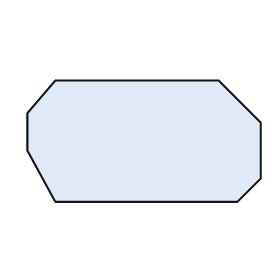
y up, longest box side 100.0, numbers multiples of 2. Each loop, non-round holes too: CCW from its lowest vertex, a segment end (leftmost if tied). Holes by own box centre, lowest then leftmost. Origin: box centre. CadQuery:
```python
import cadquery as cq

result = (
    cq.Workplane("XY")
    .moveTo(-38.0, -26.0)
    .lineTo(40.0, -26.0)
    .lineTo(50.0, -16.0)
    .lineTo(50.0, 8.0)
    .lineTo(32.0, 26.0)
    .lineTo(-38.0, 26.0)
    .lineTo(-50.0, 12.0)
    .lineTo(-50.0, -4.0)
    .close()
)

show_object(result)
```